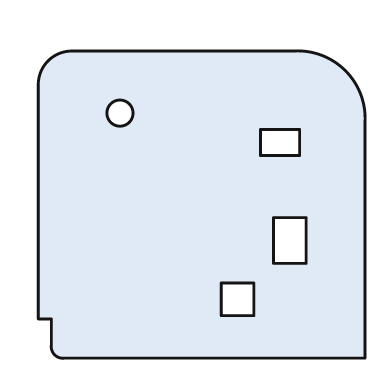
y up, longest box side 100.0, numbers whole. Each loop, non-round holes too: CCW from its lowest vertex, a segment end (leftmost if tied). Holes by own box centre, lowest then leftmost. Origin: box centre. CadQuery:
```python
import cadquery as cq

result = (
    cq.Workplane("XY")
    .moveTo(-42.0, -47.0)
    .lineTo(50.0, -47.0)
    .lineTo(50.0, 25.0)
    .threePointArc((44.0, 41.0), (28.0, 47.0))
    .lineTo(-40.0, 47.0)
    .threePointArc((-47.0, 44.0), (-50.0, 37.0))
    .lineTo(-50.0, -35.0)
    .lineTo(-46.0, -35.0)
    .lineTo(-46.0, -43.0)
    .threePointArc((-45.0, -46.0), (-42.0, -47.0))
    .close()
    .moveTo(6.0, -34.0)
    .lineTo(16.0, -34.0)
    .lineTo(16.0, -24.0)
    .lineTo(6.0, -24.0)
    .close()
    .moveTo(22.0, -18.0)
    .lineTo(32.0, -18.0)
    .lineTo(32.0, -4.0)
    .lineTo(22.0, -4.0)
    .close()
    .moveTo(18.0, 15.0)
    .lineTo(30.0, 15.0)
    .lineTo(30.0, 23.0)
    .lineTo(18.0, 23.0)
    .close()
    .moveTo(-25.0, 28.0)
    .circle(4.0)
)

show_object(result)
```